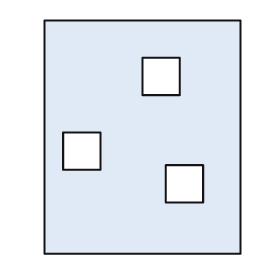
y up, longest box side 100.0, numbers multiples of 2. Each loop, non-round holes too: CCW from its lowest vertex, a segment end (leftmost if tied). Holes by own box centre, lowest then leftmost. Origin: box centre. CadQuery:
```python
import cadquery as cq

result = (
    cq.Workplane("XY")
    .moveTo(-42.0, -50.0)
    .lineTo(42.0, -50.0)
    .lineTo(42.0, 50.0)
    .lineTo(-42.0, 50.0)
    .close()
    .moveTo(10.0, -28.0)
    .lineTo(26.0, -28.0)
    .lineTo(26.0, -12.0)
    .lineTo(10.0, -12.0)
    .close()
    .moveTo(-34.0, -14.0)
    .lineTo(-18.0, -14.0)
    .lineTo(-18.0, 2.0)
    .lineTo(-34.0, 2.0)
    .close()
    .moveTo(0.0, 18.0)
    .lineTo(16.0, 18.0)
    .lineTo(16.0, 34.0)
    .lineTo(0.0, 34.0)
    .close()
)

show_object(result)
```